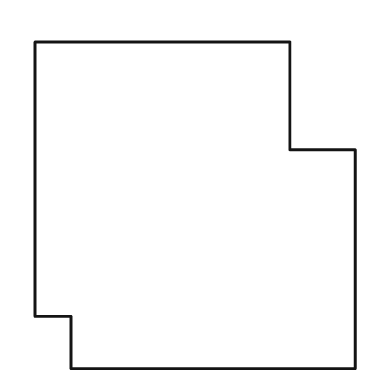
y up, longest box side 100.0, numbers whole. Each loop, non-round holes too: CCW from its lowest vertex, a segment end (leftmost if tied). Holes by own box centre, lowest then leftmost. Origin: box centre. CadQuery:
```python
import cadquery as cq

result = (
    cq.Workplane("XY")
    .moveTo(-38.0, -50.0)
    .lineTo(49.0, -50.0)
    .lineTo(49.0, 17.0)
    .lineTo(29.0, 17.0)
    .lineTo(29.0, 50.0)
    .lineTo(-49.0, 50.0)
    .lineTo(-49.0, -34.0)
    .lineTo(-38.0, -34.0)
    .close()
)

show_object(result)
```